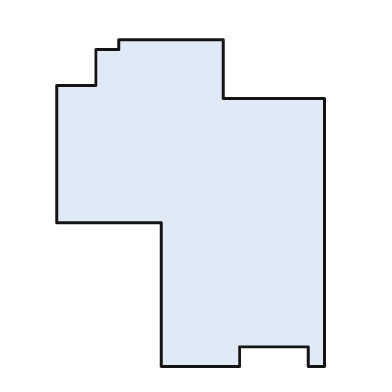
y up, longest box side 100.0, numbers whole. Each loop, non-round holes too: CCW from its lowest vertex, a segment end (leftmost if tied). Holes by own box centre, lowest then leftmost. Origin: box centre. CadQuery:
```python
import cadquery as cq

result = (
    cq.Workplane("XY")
    .moveTo(-9.0, -50.0)
    .lineTo(15.0, -50.0)
    .lineTo(15.0, -44.0)
    .lineTo(36.0, -44.0)
    .lineTo(36.0, -50.0)
    .lineTo(41.0, -50.0)
    .lineTo(41.0, 32.0)
    .lineTo(10.0, 32.0)
    .lineTo(10.0, 50.0)
    .lineTo(-22.0, 50.0)
    .lineTo(-22.0, 47.0)
    .lineTo(-29.0, 47.0)
    .lineTo(-29.0, 36.0)
    .lineTo(-41.0, 36.0)
    .lineTo(-41.0, -6.0)
    .lineTo(-9.0, -6.0)
    .close()
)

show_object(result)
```